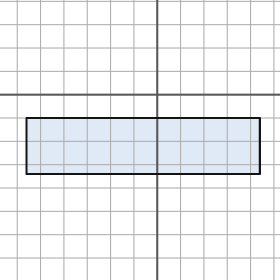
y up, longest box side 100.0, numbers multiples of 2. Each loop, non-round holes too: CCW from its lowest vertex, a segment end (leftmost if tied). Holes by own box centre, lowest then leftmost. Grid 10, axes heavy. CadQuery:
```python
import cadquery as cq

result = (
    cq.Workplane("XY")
    .moveTo(-56.0, -34.0)
    .lineTo(44.0, -34.0)
    .lineTo(44.0, -10.0)
    .lineTo(-56.0, -10.0)
    .close()
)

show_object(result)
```